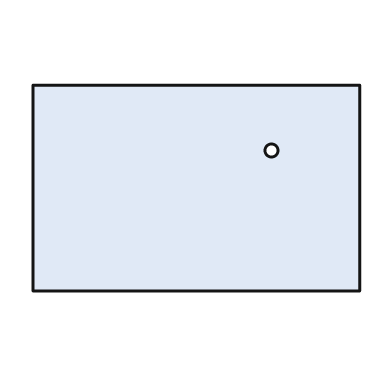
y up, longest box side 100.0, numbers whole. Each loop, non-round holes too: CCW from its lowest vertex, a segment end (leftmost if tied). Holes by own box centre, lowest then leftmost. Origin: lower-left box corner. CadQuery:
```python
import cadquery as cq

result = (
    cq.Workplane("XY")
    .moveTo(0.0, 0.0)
    .lineTo(100.0, 0.0)
    .lineTo(100.0, 63.0)
    .lineTo(0.0, 63.0)
    .close()
    .moveTo(73.0, 43.0)
    .circle(2.0)
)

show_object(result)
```